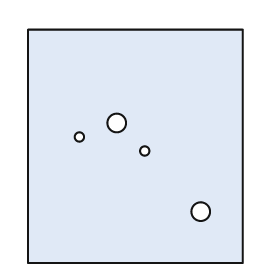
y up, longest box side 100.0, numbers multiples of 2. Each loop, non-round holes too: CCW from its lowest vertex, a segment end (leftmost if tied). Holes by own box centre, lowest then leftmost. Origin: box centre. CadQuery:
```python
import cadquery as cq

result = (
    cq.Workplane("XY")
    .moveTo(-46.0, -50.0)
    .lineTo(46.0, -50.0)
    .lineTo(46.0, 50.0)
    .lineTo(-46.0, 50.0)
    .close()
    .moveTo(28.0, -28.0)
    .circle(4.0)
    .moveTo(4.0, -2.0)
    .circle(2.0)
    .moveTo(-24.0, 4.0)
    .circle(2.0)
    .moveTo(-8.0, 10.0)
    .circle(4.0)
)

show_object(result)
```